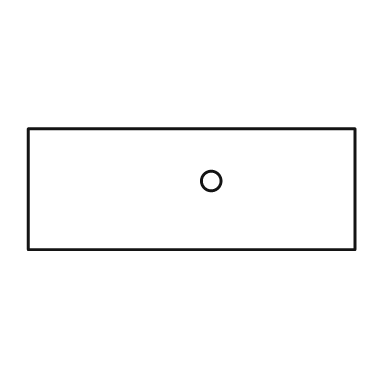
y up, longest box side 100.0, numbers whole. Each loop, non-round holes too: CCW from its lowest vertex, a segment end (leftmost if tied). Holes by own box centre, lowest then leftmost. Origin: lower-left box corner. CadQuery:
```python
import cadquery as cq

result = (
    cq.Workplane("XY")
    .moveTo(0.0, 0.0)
    .lineTo(100.0, 0.0)
    .lineTo(100.0, 37.0)
    .lineTo(0.0, 37.0)
    .close()
    .moveTo(56.0, 21.0)
    .circle(3.0)
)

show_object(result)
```